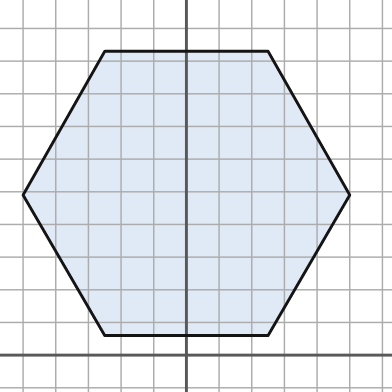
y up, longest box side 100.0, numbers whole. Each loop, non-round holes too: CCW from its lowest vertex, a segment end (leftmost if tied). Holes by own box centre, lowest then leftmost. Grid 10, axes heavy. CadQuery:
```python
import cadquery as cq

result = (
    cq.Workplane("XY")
    .moveTo(-25.0, 6.0)
    .lineTo(25.0, 6.0)
    .lineTo(50.0, 49.0)
    .lineTo(25.0, 93.0)
    .lineTo(-25.0, 93.0)
    .lineTo(-50.0, 49.0)
    .close()
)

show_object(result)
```